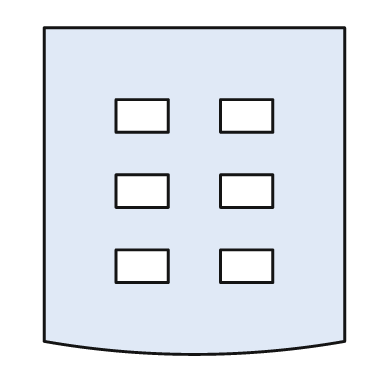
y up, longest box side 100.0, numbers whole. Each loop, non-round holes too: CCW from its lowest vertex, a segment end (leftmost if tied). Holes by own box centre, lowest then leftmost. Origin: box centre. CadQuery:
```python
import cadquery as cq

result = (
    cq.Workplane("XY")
    .moveTo(-46.0, -46.0)
    .threePointArc((0.0, -50.0), (46.0, -46.0))
    .lineTo(46.0, 50.0)
    .lineTo(-46.0, 50.0)
    .close()
    .moveTo(-24.0, -28.0)
    .lineTo(-8.0, -28.0)
    .lineTo(-8.0, -18.0)
    .lineTo(-24.0, -18.0)
    .close()
    .moveTo(8.0, -28.0)
    .lineTo(24.0, -28.0)
    .lineTo(24.0, -18.0)
    .lineTo(8.0, -18.0)
    .close()
    .moveTo(-24.0, -5.0)
    .lineTo(-8.0, -5.0)
    .lineTo(-8.0, 5.0)
    .lineTo(-24.0, 5.0)
    .close()
    .moveTo(8.0, -5.0)
    .lineTo(24.0, -5.0)
    .lineTo(24.0, 5.0)
    .lineTo(8.0, 5.0)
    .close()
    .moveTo(-24.0, 18.0)
    .lineTo(-8.0, 18.0)
    .lineTo(-8.0, 28.0)
    .lineTo(-24.0, 28.0)
    .close()
    .moveTo(8.0, 18.0)
    .lineTo(24.0, 18.0)
    .lineTo(24.0, 28.0)
    .lineTo(8.0, 28.0)
    .close()
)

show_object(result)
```